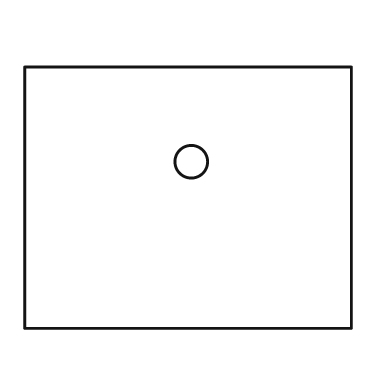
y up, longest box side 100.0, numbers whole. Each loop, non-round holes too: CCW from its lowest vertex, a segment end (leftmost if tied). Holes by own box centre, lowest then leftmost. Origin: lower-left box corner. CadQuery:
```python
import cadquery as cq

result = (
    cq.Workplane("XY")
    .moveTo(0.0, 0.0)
    .lineTo(100.0, 0.0)
    .lineTo(100.0, 80.0)
    .lineTo(0.0, 80.0)
    .close()
    .moveTo(51.0, 51.0)
    .circle(5.0)
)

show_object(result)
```